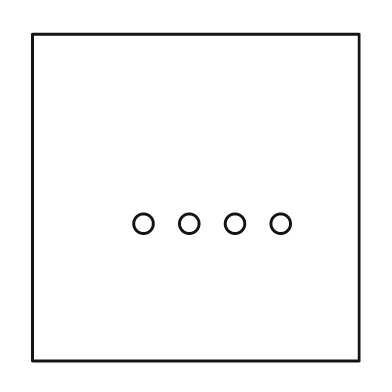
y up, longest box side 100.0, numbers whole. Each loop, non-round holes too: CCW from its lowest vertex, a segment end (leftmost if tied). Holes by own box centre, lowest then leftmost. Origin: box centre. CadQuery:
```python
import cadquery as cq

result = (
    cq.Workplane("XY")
    .moveTo(-50.0, -50.0)
    .lineTo(50.0, -50.0)
    .lineTo(50.0, 50.0)
    .lineTo(-50.0, 50.0)
    .close()
    .moveTo(-16.0, -8.0)
    .circle(3.0)
    .moveTo(-2.0, -8.0)
    .circle(3.0)
    .moveTo(12.0, -8.0)
    .circle(3.0)
    .moveTo(26.0, -8.0)
    .circle(3.0)
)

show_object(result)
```